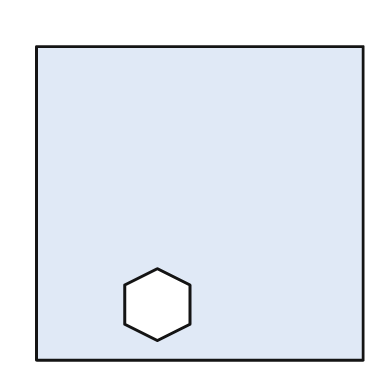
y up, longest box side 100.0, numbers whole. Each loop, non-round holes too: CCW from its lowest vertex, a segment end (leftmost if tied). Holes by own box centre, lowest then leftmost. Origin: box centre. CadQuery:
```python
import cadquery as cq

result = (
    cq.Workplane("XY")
    .moveTo(-50.0, -48.0)
    .lineTo(50.0, -48.0)
    .lineTo(50.0, 48.0)
    .lineTo(-50.0, 48.0)
    .close()
    .moveTo(-13.0, -42.0)
    .lineTo(-3.0, -37.0)
    .lineTo(-3.0, -25.0)
    .lineTo(-13.0, -20.0)
    .lineTo(-23.0, -25.0)
    .lineTo(-23.0, -37.0)
    .close()
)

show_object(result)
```